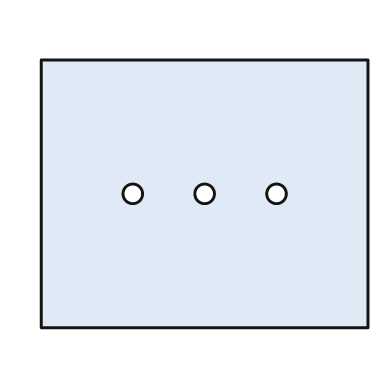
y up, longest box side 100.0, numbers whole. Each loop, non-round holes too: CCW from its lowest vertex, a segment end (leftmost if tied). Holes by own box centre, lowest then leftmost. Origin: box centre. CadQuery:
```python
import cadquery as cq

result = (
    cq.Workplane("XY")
    .moveTo(-50.0, -41.0)
    .lineTo(50.0, -41.0)
    .lineTo(50.0, 41.0)
    .lineTo(-50.0, 41.0)
    .close()
    .moveTo(-22.0, 0.0)
    .circle(3.0)
    .moveTo(0.0, 0.0)
    .circle(3.0)
    .moveTo(22.0, 0.0)
    .circle(3.0)
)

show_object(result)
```